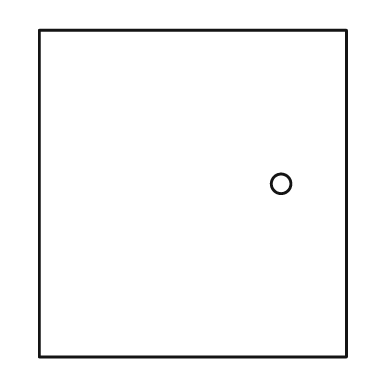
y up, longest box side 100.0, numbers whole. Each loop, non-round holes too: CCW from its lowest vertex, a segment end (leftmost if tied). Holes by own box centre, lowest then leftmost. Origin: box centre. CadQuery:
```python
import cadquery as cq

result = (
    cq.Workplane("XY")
    .moveTo(-47.0, -50.0)
    .lineTo(47.0, -50.0)
    .lineTo(47.0, 50.0)
    .lineTo(-47.0, 50.0)
    .close()
    .moveTo(27.0, 3.0)
    .circle(3.0)
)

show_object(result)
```